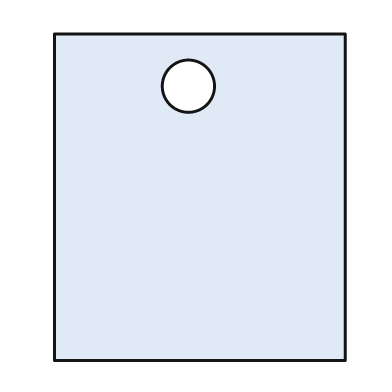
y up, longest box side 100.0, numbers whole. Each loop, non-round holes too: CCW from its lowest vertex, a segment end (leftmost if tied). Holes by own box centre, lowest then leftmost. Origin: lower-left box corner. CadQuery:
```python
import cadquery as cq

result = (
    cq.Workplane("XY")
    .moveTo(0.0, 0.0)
    .lineTo(89.0, 0.0)
    .lineTo(89.0, 100.0)
    .lineTo(0.0, 100.0)
    .close()
    .moveTo(41.0, 84.0)
    .circle(8.0)
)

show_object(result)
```